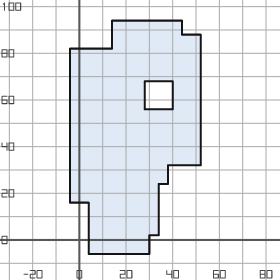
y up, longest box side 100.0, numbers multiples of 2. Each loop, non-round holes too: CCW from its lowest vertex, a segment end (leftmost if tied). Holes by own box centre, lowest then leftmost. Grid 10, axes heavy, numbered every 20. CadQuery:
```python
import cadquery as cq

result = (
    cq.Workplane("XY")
    .moveTo(4.0, -6.0)
    .lineTo(30.0, -6.0)
    .lineTo(30.0, 2.0)
    .lineTo(34.0, 2.0)
    .lineTo(34.0, 24.0)
    .lineTo(38.0, 24.0)
    .lineTo(38.0, 32.0)
    .lineTo(52.0, 32.0)
    .lineTo(52.0, 88.0)
    .lineTo(44.0, 88.0)
    .lineTo(44.0, 94.0)
    .lineTo(14.0, 94.0)
    .lineTo(14.0, 82.0)
    .lineTo(-4.0, 82.0)
    .lineTo(-4.0, 16.0)
    .lineTo(4.0, 16.0)
    .close()
    .moveTo(28.0, 56.0)
    .lineTo(40.0, 56.0)
    .lineTo(40.0, 68.0)
    .lineTo(28.0, 68.0)
    .close()
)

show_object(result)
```